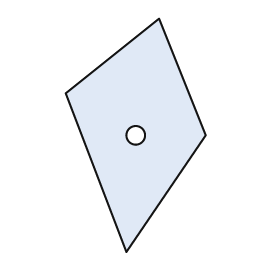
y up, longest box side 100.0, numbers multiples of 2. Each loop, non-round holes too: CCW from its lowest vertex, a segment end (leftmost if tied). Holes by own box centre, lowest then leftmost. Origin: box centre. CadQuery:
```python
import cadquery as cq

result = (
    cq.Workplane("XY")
    .moveTo(-4.0, -50.0)
    .lineTo(30.0, 0.0)
    .lineTo(10.0, 50.0)
    .lineTo(-30.0, 18.0)
    .close()
    .moveTo(0.0, 0.0)
    .circle(4.0)
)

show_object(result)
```